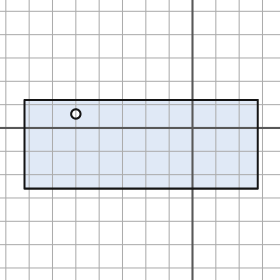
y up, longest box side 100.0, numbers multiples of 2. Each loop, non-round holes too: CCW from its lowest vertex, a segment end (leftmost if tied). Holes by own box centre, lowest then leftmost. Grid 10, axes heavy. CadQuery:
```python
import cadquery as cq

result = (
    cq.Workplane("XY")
    .moveTo(-72.0, -26.0)
    .lineTo(28.0, -26.0)
    .lineTo(28.0, 12.0)
    .lineTo(-72.0, 12.0)
    .close()
    .moveTo(-50.0, 6.0)
    .circle(2.0)
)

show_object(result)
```